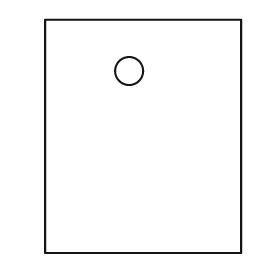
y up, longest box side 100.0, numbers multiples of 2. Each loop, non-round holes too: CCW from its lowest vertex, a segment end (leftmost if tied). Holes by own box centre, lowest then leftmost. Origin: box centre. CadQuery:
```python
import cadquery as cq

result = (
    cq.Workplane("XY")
    .moveTo(-42.0, -50.0)
    .lineTo(42.0, -50.0)
    .lineTo(42.0, 50.0)
    .lineTo(-42.0, 50.0)
    .close()
    .moveTo(-6.0, 28.0)
    .circle(6.0)
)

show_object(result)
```